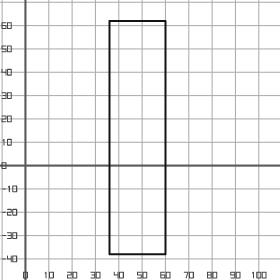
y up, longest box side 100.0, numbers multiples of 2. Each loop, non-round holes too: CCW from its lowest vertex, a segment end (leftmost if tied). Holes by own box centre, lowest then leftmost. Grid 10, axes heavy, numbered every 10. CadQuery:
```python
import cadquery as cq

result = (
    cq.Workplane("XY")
    .moveTo(36.0, -38.0)
    .lineTo(60.0, -38.0)
    .lineTo(60.0, 62.0)
    .lineTo(36.0, 62.0)
    .close()
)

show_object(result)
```